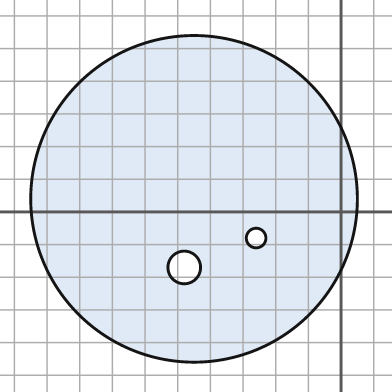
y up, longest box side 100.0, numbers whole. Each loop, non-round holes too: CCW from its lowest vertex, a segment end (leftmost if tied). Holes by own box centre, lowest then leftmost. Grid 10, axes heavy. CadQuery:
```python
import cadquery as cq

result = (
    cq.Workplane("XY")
    .moveTo(-45.0, 4.0)
    .circle(50.0)
    .moveTo(-48.0, -17.0)
    .circle(5.0)
    .moveTo(-26.0, -8.0)
    .circle(3.0)
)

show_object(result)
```